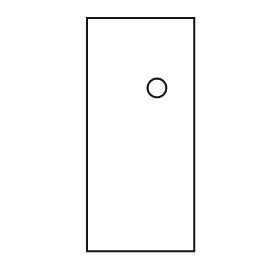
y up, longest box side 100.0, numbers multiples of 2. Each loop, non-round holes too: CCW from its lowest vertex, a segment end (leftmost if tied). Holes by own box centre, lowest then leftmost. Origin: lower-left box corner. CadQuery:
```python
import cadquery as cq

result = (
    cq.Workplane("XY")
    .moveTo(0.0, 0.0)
    .lineTo(46.0, 0.0)
    .lineTo(46.0, 100.0)
    .lineTo(0.0, 100.0)
    .close()
    .moveTo(30.0, 70.0)
    .circle(4.0)
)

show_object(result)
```